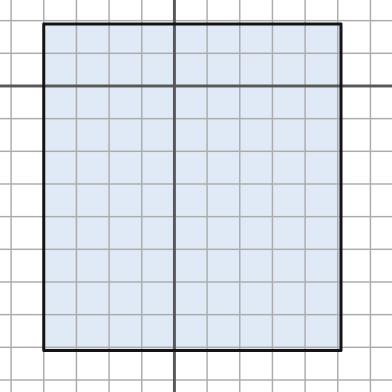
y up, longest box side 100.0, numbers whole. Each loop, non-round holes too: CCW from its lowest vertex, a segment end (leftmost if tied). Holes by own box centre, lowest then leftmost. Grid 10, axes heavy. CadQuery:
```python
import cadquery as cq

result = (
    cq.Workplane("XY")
    .moveTo(-40.0, -81.0)
    .lineTo(51.0, -81.0)
    .lineTo(51.0, 19.0)
    .lineTo(-40.0, 19.0)
    .close()
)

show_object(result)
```